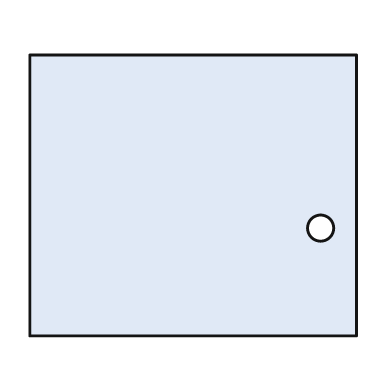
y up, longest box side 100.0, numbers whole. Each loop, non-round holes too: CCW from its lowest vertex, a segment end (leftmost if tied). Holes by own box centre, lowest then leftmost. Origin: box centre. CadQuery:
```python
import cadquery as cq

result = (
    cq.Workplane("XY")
    .moveTo(-50.0, -43.0)
    .lineTo(50.0, -43.0)
    .lineTo(50.0, 43.0)
    .lineTo(-50.0, 43.0)
    .close()
    .moveTo(39.0, -10.0)
    .circle(4.0)
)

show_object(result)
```